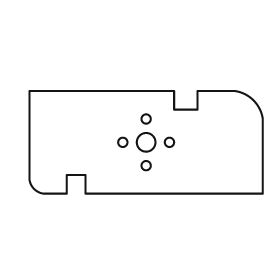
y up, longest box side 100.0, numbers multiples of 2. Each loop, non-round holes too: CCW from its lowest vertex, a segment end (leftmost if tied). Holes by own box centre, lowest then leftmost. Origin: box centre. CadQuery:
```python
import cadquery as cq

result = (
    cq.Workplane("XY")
    .moveTo(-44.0, -22.0)
    .lineTo(-34.0, -22.0)
    .lineTo(-34.0, -14.0)
    .lineTo(-26.0, -14.0)
    .lineTo(-26.0, -22.0)
    .lineTo(50.0, -22.0)
    .lineTo(50.0, 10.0)
    .threePointArc((46.0, 18.0), (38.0, 22.0))
    .lineTo(22.0, 22.0)
    .lineTo(22.0, 14.0)
    .lineTo(12.0, 14.0)
    .lineTo(12.0, 22.0)
    .lineTo(-50.0, 22.0)
    .lineTo(-50.0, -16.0)
    .threePointArc((-48.0, -20.0), (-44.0, -22.0))
    .close()
    .moveTo(0.0, -10.0)
    .circle(2.0)
    .moveTo(-10.0, 0.0)
    .circle(2.0)
    .moveTo(0.0, 0.0)
    .circle(4.0)
    .moveTo(10.0, 0.0)
    .circle(2.0)
    .moveTo(0.0, 10.0)
    .circle(2.0)
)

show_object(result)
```